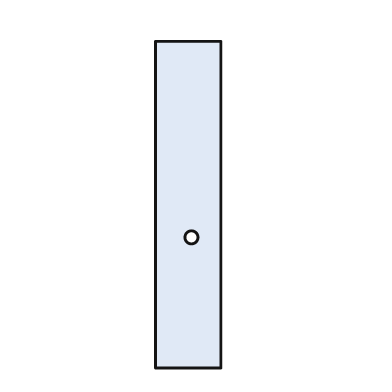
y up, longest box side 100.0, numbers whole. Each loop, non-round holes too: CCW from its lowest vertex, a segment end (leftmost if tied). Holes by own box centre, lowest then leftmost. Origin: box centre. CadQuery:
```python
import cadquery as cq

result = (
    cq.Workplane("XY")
    .moveTo(-10.0, -50.0)
    .lineTo(10.0, -50.0)
    .lineTo(10.0, 50.0)
    .lineTo(-10.0, 50.0)
    .close()
    .moveTo(1.0, -10.0)
    .circle(2.0)
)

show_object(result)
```